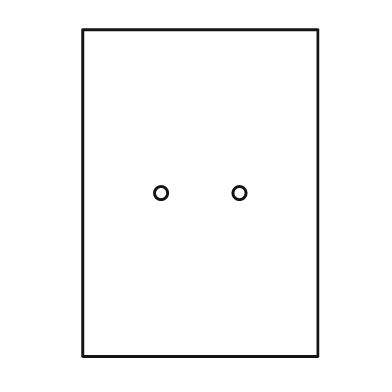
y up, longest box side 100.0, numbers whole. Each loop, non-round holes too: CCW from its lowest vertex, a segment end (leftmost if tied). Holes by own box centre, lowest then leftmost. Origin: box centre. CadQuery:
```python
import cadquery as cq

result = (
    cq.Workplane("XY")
    .moveTo(-36.0, -50.0)
    .lineTo(36.0, -50.0)
    .lineTo(36.0, 50.0)
    .lineTo(-36.0, 50.0)
    .close()
    .moveTo(-12.0, 0.0)
    .circle(2.0)
    .moveTo(12.0, 0.0)
    .circle(2.0)
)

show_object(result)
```